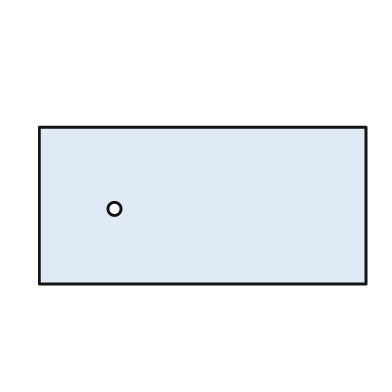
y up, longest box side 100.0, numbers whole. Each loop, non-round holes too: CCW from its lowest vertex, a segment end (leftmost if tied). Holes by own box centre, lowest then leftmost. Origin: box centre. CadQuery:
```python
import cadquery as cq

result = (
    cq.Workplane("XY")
    .moveTo(-50.0, -24.0)
    .lineTo(50.0, -24.0)
    .lineTo(50.0, 24.0)
    .lineTo(-50.0, 24.0)
    .close()
    .moveTo(-27.0, -1.0)
    .circle(2.0)
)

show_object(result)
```